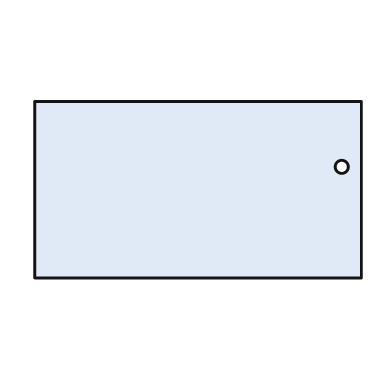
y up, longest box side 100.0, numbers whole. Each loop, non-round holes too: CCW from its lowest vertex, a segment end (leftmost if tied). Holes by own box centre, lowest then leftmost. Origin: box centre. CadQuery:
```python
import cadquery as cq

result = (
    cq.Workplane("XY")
    .moveTo(-50.0, -27.0)
    .lineTo(50.0, -27.0)
    .lineTo(50.0, 27.0)
    .lineTo(-50.0, 27.0)
    .close()
    .moveTo(44.0, 7.0)
    .circle(2.0)
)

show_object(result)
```